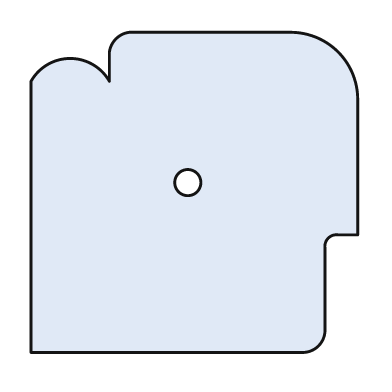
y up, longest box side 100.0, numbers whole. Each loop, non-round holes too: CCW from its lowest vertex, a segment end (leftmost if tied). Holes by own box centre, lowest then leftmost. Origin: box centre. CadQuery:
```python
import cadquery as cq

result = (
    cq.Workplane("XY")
    .moveTo(-50.0, -49.0)
    .lineTo(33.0, -49.0)
    .threePointArc((38.0, -47.0), (40.0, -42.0))
    .lineTo(40.0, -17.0)
    .threePointArc((41.0, -14.0), (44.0, -13.0))
    .lineTo(50.0, -13.0)
    .lineTo(50.0, 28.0)
    .threePointArc((44.0, 43.0), (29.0, 49.0))
    .lineTo(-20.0, 49.0)
    .threePointArc((-24.0, 47.0), (-26.0, 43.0))
    .lineTo(-26.0, 34.0)
    .threePointArc((-38.0, 41.0), (-50.0, 34.0))
    .close()
    .moveTo(-2.0, 3.0)
    .circle(4.0)
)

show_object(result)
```